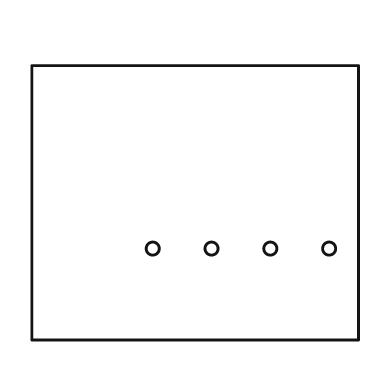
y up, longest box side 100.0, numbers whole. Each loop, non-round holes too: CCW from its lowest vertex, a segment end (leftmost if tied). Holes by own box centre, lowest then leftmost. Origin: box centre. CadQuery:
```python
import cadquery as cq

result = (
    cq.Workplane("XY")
    .moveTo(-50.0, -42.0)
    .lineTo(50.0, -42.0)
    .lineTo(50.0, 42.0)
    .lineTo(-50.0, 42.0)
    .close()
    .moveTo(-13.0, -14.0)
    .circle(2.0)
    .moveTo(5.0, -14.0)
    .circle(2.0)
    .moveTo(23.0, -14.0)
    .circle(2.0)
    .moveTo(41.0, -14.0)
    .circle(2.0)
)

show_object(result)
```